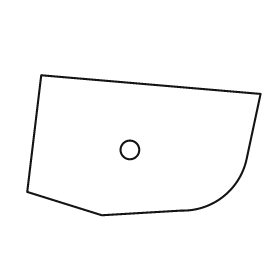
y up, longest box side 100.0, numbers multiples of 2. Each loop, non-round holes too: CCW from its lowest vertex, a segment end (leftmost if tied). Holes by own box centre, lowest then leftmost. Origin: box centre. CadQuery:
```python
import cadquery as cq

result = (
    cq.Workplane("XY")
    .moveTo(-18.0, -30.0)
    .lineTo(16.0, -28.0)
    .threePointArc((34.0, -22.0), (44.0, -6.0))
    .lineTo(50.0, 22.0)
    .lineTo(-44.0, 30.0)
    .lineTo(-50.0, -20.0)
    .close()
    .moveTo(-6.0, -2.0)
    .circle(4.0)
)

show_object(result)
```